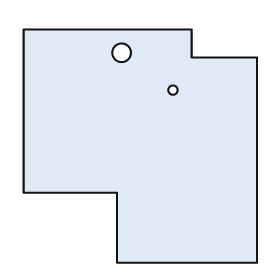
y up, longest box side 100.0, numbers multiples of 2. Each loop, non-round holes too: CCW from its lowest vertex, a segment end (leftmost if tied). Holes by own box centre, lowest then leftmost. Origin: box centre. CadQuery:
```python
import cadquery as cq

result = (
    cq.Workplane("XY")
    .moveTo(-10.0, -50.0)
    .lineTo(50.0, -50.0)
    .lineTo(50.0, 38.0)
    .lineTo(22.0, 38.0)
    .lineTo(22.0, 50.0)
    .lineTo(-50.0, 50.0)
    .lineTo(-50.0, -20.0)
    .lineTo(-10.0, -20.0)
    .close()
    .moveTo(14.0, 24.0)
    .circle(2.0)
    .moveTo(-8.0, 40.0)
    .circle(4.0)
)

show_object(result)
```